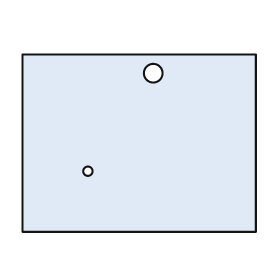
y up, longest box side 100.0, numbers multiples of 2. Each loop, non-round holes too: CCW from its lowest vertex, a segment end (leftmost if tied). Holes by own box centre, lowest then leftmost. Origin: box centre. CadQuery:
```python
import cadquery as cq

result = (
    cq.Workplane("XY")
    .moveTo(-50.0, -38.0)
    .lineTo(50.0, -38.0)
    .lineTo(50.0, 38.0)
    .lineTo(-50.0, 38.0)
    .close()
    .moveTo(-22.0, -12.0)
    .circle(2.0)
    .moveTo(6.0, 30.0)
    .circle(4.0)
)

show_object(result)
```